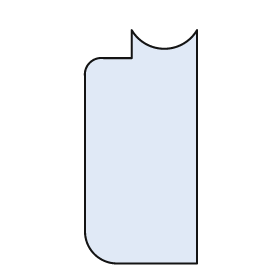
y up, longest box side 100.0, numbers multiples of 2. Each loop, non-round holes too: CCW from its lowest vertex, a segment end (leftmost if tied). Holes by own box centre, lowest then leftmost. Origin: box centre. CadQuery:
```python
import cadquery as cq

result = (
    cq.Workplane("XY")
    .moveTo(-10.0, -50.0)
    .lineTo(24.0, -50.0)
    .lineTo(24.0, 50.0)
    .threePointArc((10.0, 42.0), (-4.0, 50.0))
    .lineTo(-4.0, 38.0)
    .lineTo(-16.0, 38.0)
    .threePointArc((-22.0, 36.0), (-24.0, 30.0))
    .lineTo(-24.0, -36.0)
    .threePointArc((-20.0, -46.0), (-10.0, -50.0))
    .close()
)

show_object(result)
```